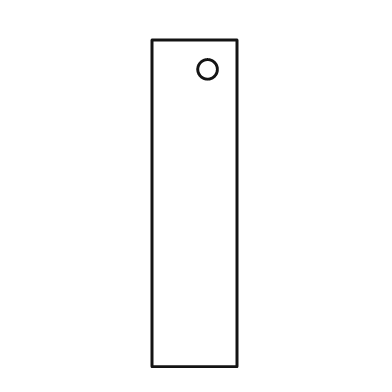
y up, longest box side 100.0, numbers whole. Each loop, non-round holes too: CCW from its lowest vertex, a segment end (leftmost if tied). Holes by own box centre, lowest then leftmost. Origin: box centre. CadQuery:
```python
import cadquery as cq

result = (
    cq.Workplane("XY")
    .moveTo(-13.0, -50.0)
    .lineTo(13.0, -50.0)
    .lineTo(13.0, 50.0)
    .lineTo(-13.0, 50.0)
    .close()
    .moveTo(4.0, 41.0)
    .circle(3.0)
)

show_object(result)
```